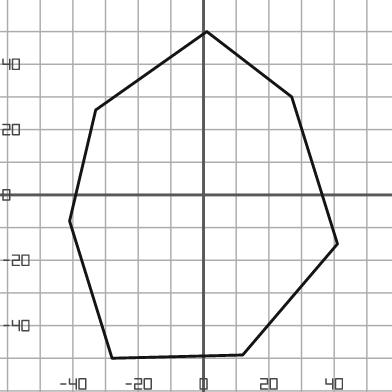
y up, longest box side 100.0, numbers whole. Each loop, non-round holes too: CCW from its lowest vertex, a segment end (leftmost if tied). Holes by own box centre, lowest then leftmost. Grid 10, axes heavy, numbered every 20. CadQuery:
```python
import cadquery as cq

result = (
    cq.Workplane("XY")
    .moveTo(-28.0, -50.0)
    .lineTo(12.0, -49.0)
    .lineTo(41.0, -15.0)
    .lineTo(27.0, 30.0)
    .lineTo(1.0, 50.0)
    .lineTo(-33.0, 26.0)
    .lineTo(-41.0, -8.0)
    .close()
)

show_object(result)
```